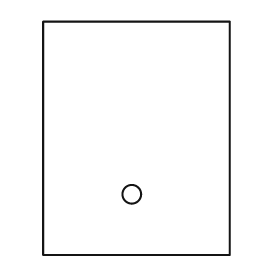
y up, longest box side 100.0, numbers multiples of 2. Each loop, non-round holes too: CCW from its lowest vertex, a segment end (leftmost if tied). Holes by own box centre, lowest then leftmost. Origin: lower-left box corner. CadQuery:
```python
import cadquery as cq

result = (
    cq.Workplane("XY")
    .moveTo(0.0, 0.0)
    .lineTo(80.0, 0.0)
    .lineTo(80.0, 100.0)
    .lineTo(0.0, 100.0)
    .close()
    .moveTo(38.0, 26.0)
    .circle(4.0)
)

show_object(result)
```